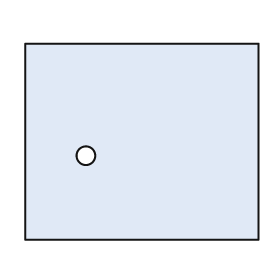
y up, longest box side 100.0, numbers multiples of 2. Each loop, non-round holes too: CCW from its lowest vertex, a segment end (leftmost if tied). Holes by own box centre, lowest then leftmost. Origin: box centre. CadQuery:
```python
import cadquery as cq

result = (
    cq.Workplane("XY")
    .moveTo(-50.0, -42.0)
    .lineTo(50.0, -42.0)
    .lineTo(50.0, 42.0)
    .lineTo(-50.0, 42.0)
    .close()
    .moveTo(-24.0, -6.0)
    .circle(4.0)
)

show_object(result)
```